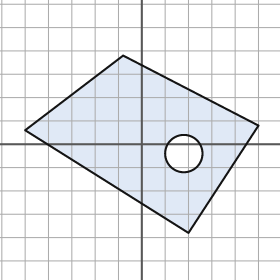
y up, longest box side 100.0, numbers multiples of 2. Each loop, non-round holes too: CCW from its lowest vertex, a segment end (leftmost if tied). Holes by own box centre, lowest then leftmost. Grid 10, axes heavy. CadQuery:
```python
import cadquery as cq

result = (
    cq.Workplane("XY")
    .moveTo(20.0, -38.0)
    .lineTo(50.0, 8.0)
    .lineTo(-8.0, 38.0)
    .lineTo(-50.0, 6.0)
    .close()
    .moveTo(18.0, -4.0)
    .circle(8.0)
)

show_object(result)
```